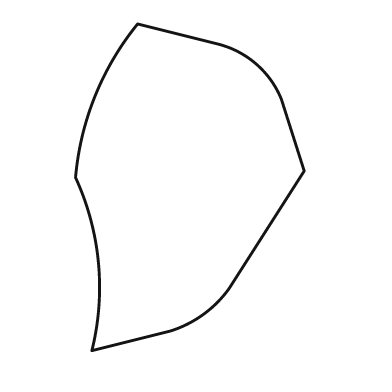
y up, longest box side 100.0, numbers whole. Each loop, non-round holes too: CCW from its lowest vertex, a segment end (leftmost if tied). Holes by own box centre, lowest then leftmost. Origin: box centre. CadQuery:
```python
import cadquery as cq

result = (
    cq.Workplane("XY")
    .moveTo(-30.0, -50.0)
    .lineTo(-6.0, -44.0)
    .threePointArc((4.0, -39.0), (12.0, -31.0))
    .lineTo(35.0, 5.0)
    .lineTo(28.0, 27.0)
    .threePointArc((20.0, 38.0), (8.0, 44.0))
    .lineTo(-16.0, 50.0)
    .threePointArc((-29.0, 28.0), (-35.0, 3.0))
    .threePointArc((-28.0, -23.0), (-30.0, -50.0))
    .close()
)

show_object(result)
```